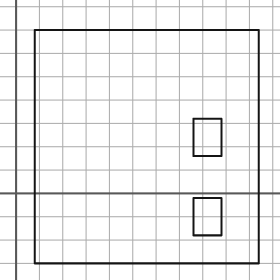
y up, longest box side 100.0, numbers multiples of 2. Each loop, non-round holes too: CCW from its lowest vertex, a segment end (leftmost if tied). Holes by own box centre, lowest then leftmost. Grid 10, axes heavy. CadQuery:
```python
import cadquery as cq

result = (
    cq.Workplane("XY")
    .moveTo(8.0, -30.0)
    .lineTo(104.0, -30.0)
    .lineTo(104.0, 70.0)
    .lineTo(8.0, 70.0)
    .close()
    .moveTo(76.0, -18.0)
    .lineTo(88.0, -18.0)
    .lineTo(88.0, -2.0)
    .lineTo(76.0, -2.0)
    .close()
    .moveTo(76.0, 16.0)
    .lineTo(88.0, 16.0)
    .lineTo(88.0, 32.0)
    .lineTo(76.0, 32.0)
    .close()
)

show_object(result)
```